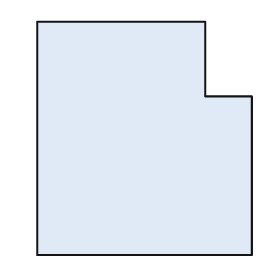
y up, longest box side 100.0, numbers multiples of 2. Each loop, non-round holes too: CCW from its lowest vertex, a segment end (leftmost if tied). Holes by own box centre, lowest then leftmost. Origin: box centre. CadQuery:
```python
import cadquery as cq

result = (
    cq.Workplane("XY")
    .moveTo(-46.0, -50.0)
    .lineTo(46.0, -50.0)
    .lineTo(46.0, 18.0)
    .lineTo(26.0, 18.0)
    .lineTo(26.0, 50.0)
    .lineTo(-46.0, 50.0)
    .close()
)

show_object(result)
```